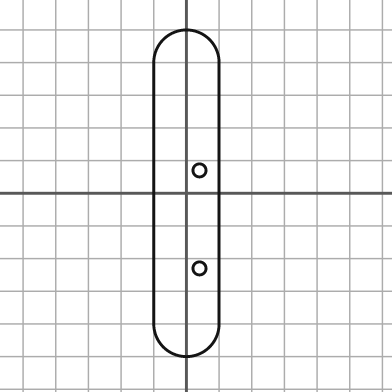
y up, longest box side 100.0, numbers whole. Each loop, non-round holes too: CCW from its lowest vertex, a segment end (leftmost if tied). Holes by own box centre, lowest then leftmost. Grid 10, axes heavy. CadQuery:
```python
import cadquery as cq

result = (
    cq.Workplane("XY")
    .moveTo(-10.0, -40.0)
    .threePointArc((0.0, -50.0), (10.0, -40.0))
    .lineTo(10.0, 40.0)
    .threePointArc((0.0, 50.0), (-10.0, 40.0))
    .close()
    .moveTo(4.0, -23.0)
    .circle(2.0)
    .moveTo(4.0, 7.0)
    .circle(2.0)
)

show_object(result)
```